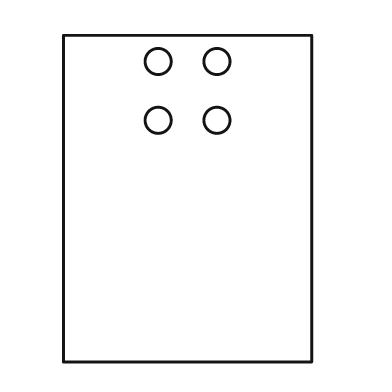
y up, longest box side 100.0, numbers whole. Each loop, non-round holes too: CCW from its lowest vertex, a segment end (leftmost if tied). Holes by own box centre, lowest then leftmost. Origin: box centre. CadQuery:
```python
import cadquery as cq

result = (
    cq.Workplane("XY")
    .moveTo(-38.0, -50.0)
    .lineTo(38.0, -50.0)
    .lineTo(38.0, 50.0)
    .lineTo(-38.0, 50.0)
    .close()
    .moveTo(-9.0, 24.0)
    .circle(4.0)
    .moveTo(9.0, 24.0)
    .circle(4.0)
    .moveTo(-9.0, 42.0)
    .circle(4.0)
    .moveTo(9.0, 42.0)
    .circle(4.0)
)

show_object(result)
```